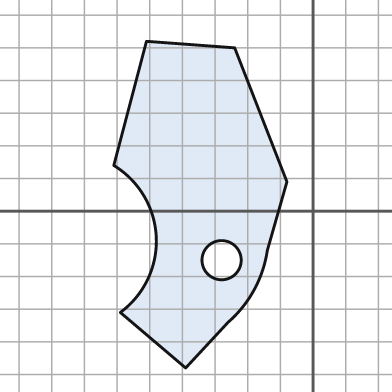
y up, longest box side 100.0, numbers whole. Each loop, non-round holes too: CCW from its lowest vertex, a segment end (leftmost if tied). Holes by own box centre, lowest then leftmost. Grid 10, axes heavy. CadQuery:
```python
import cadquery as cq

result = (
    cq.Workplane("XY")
    .moveTo(-39.0, -48.0)
    .lineTo(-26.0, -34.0)
    .threePointArc((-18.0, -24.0), (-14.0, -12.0))
    .lineTo(-8.0, 9.0)
    .lineTo(-24.0, 50.0)
    .lineTo(-51.0, 52.0)
    .lineTo(-61.0, 14.0)
    .threePointArc((-48.0, -8.0), (-59.0, -31.0))
    .close()
    .moveTo(-28.0, -15.0)
    .circle(6.0)
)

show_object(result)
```